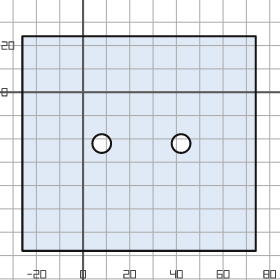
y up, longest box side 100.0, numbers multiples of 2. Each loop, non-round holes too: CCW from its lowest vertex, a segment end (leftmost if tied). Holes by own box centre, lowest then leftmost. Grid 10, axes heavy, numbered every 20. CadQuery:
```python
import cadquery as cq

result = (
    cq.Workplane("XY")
    .moveTo(-26.0, -68.0)
    .lineTo(74.0, -68.0)
    .lineTo(74.0, 24.0)
    .lineTo(-26.0, 24.0)
    .close()
    .moveTo(8.0, -22.0)
    .circle(4.0)
    .moveTo(42.0, -22.0)
    .circle(4.0)
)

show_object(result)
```